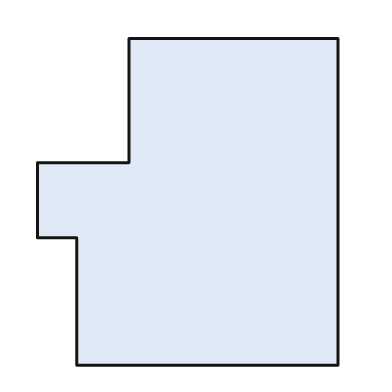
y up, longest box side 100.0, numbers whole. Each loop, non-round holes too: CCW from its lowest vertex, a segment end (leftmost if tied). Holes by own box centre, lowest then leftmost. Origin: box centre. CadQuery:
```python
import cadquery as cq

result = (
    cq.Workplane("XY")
    .moveTo(-34.0, -50.0)
    .lineTo(46.0, -50.0)
    .lineTo(46.0, 50.0)
    .lineTo(-18.0, 50.0)
    .lineTo(-18.0, 12.0)
    .lineTo(-46.0, 12.0)
    .lineTo(-46.0, -11.0)
    .lineTo(-34.0, -11.0)
    .close()
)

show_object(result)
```